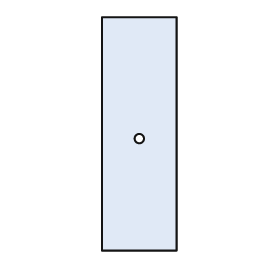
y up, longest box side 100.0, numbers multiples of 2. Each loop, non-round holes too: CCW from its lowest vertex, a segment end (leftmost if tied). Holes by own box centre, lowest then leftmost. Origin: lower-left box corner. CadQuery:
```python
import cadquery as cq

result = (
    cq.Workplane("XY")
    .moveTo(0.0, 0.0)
    .lineTo(32.0, 0.0)
    .lineTo(32.0, 100.0)
    .lineTo(0.0, 100.0)
    .close()
    .moveTo(16.0, 48.0)
    .circle(2.0)
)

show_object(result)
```